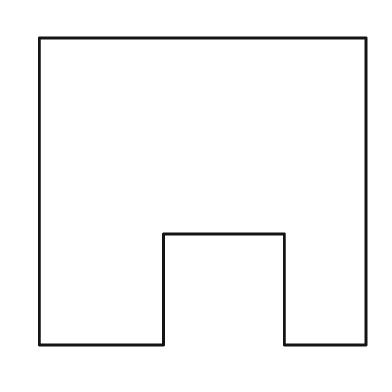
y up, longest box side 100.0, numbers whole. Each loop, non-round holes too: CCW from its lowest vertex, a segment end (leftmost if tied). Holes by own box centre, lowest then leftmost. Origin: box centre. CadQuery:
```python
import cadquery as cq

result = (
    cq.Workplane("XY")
    .moveTo(-50.0, -47.0)
    .lineTo(-12.0, -47.0)
    .lineTo(-12.0, -13.0)
    .lineTo(25.0, -13.0)
    .lineTo(25.0, -47.0)
    .lineTo(50.0, -47.0)
    .lineTo(50.0, 47.0)
    .lineTo(-50.0, 47.0)
    .close()
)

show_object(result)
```